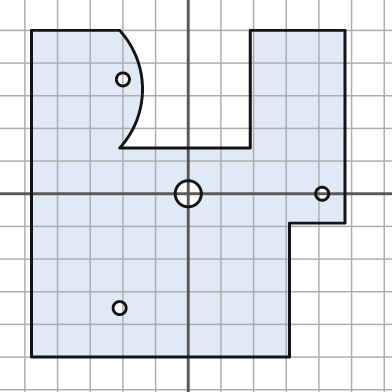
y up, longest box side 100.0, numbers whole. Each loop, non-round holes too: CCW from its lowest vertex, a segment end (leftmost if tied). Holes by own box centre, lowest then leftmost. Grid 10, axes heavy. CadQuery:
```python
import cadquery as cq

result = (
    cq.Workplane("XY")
    .moveTo(-48.0, -50.0)
    .lineTo(31.0, -50.0)
    .lineTo(31.0, -9.0)
    .lineTo(48.0, -9.0)
    .lineTo(48.0, 50.0)
    .lineTo(19.0, 50.0)
    .lineTo(19.0, 14.0)
    .lineTo(-21.0, 14.0)
    .threePointArc((-14.0, 32.0), (-21.0, 50.0))
    .lineTo(-48.0, 50.0)
    .close()
    .moveTo(-21.0, -35.0)
    .circle(2.0)
    .moveTo(0.0, 0.0)
    .circle(4.0)
    .moveTo(41.0, 0.0)
    .circle(2.0)
    .moveTo(-20.0, 35.0)
    .circle(2.0)
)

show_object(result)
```